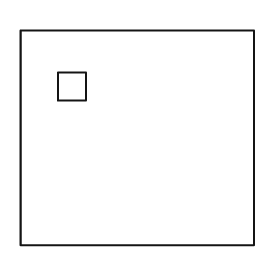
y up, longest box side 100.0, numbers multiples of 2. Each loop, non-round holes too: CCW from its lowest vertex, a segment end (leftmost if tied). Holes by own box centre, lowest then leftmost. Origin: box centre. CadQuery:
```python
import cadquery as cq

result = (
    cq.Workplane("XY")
    .moveTo(-50.0, -46.0)
    .lineTo(50.0, -46.0)
    .lineTo(50.0, 46.0)
    .lineTo(-50.0, 46.0)
    .close()
    .moveTo(-34.0, 16.0)
    .lineTo(-22.0, 16.0)
    .lineTo(-22.0, 28.0)
    .lineTo(-34.0, 28.0)
    .close()
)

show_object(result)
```